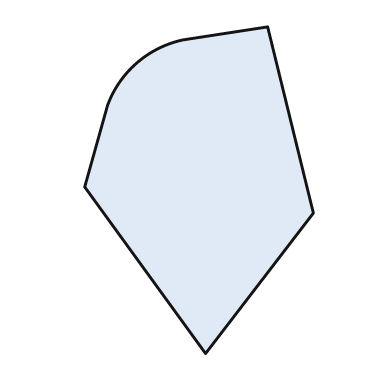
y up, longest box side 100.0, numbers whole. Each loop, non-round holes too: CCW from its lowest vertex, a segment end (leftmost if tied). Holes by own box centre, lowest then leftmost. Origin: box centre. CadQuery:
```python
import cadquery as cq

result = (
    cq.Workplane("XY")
    .moveTo(2.0, -50.0)
    .lineTo(35.0, -7.0)
    .lineTo(21.0, 50.0)
    .lineTo(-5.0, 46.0)
    .threePointArc((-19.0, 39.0), (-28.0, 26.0))
    .lineTo(-35.0, 1.0)
    .close()
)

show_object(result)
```